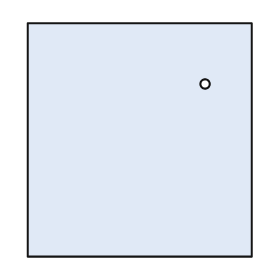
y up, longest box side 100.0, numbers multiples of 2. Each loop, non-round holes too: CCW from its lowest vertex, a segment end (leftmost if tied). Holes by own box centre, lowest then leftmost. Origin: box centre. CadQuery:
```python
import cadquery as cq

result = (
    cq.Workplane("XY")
    .moveTo(-48.0, -50.0)
    .lineTo(48.0, -50.0)
    .lineTo(48.0, 50.0)
    .lineTo(-48.0, 50.0)
    .close()
    .moveTo(28.0, 24.0)
    .circle(2.0)
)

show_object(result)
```